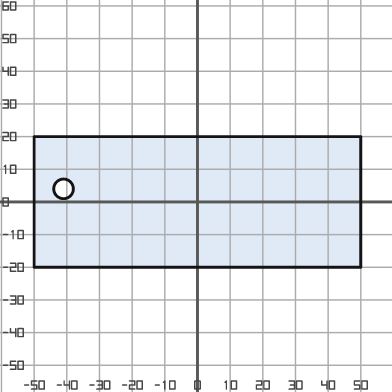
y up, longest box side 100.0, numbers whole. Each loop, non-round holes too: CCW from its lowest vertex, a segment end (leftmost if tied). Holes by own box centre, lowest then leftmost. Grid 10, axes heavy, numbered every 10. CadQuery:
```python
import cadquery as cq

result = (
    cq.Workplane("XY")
    .moveTo(-50.0, -20.0)
    .lineTo(50.0, -20.0)
    .lineTo(50.0, 20.0)
    .lineTo(-50.0, 20.0)
    .close()
    .moveTo(-41.0, 4.0)
    .circle(3.0)
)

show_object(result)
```